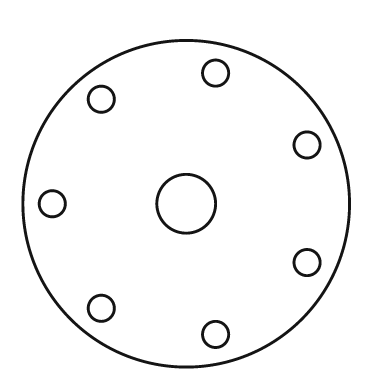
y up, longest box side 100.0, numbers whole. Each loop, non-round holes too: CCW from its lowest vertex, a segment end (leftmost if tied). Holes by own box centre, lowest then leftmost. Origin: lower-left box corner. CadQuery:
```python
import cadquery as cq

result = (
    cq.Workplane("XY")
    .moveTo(50.0, 50.0)
    .circle(50.0)
    .moveTo(59.0, 10.0)
    .circle(4.0)
    .moveTo(24.0, 18.0)
    .circle(4.0)
    .moveTo(87.0, 32.0)
    .circle(4.0)
    .moveTo(9.0, 50.0)
    .circle(4.0)
    .moveTo(50.0, 50.0)
    .circle(9.0)
    .moveTo(87.0, 68.0)
    .circle(4.0)
    .moveTo(24.0, 82.0)
    .circle(4.0)
    .moveTo(59.0, 90.0)
    .circle(4.0)
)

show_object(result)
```